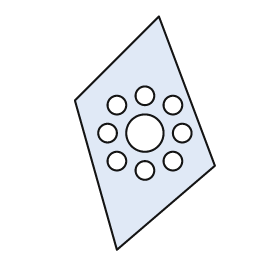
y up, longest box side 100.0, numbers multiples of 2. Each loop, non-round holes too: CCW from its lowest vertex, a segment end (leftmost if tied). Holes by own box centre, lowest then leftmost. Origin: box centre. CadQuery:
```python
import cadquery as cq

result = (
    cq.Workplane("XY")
    .moveTo(-12.0, -50.0)
    .lineTo(30.0, -14.0)
    .lineTo(6.0, 50.0)
    .lineTo(-30.0, 14.0)
    .close()
    .moveTo(0.0, -16.0)
    .circle(4.0)
    .moveTo(-12.0, -12.0)
    .circle(4.0)
    .moveTo(12.0, -12.0)
    .circle(4.0)
    .moveTo(-16.0, 0.0)
    .circle(4.0)
    .moveTo(0.0, 0.0)
    .circle(8.0)
    .moveTo(16.0, 0.0)
    .circle(4.0)
    .moveTo(-12.0, 12.0)
    .circle(4.0)
    .moveTo(12.0, 12.0)
    .circle(4.0)
    .moveTo(0.0, 16.0)
    .circle(4.0)
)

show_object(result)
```